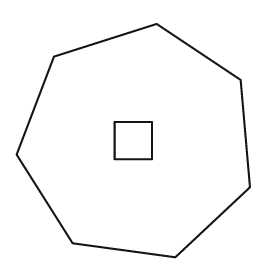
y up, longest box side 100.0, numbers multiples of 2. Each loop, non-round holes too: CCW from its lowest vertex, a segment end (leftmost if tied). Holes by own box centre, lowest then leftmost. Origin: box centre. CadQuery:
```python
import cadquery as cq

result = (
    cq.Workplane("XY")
    .moveTo(18.0, -50.0)
    .lineTo(50.0, -20.0)
    .lineTo(46.0, 26.0)
    .lineTo(10.0, 50.0)
    .lineTo(-34.0, 36.0)
    .lineTo(-50.0, -6.0)
    .lineTo(-26.0, -44.0)
    .close()
    .moveTo(-8.0, -8.0)
    .lineTo(8.0, -8.0)
    .lineTo(8.0, 8.0)
    .lineTo(-8.0, 8.0)
    .close()
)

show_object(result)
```